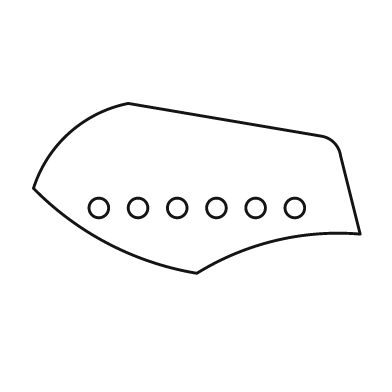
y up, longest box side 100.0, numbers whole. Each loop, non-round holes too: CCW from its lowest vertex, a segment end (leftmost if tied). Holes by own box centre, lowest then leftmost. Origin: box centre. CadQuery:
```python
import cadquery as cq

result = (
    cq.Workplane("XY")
    .moveTo(0.0, -26.0)
    .threePointArc((24.0, -16.0), (50.0, -14.0))
    .lineTo(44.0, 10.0)
    .threePointArc((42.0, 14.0), (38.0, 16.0))
    .lineTo(-21.0, 26.0)
    .threePointArc((-39.0, 17.0), (-50.0, 0.0))
    .threePointArc((-27.0, -17.0), (0.0, -26.0))
    .close()
    .moveTo(-30.0, -6.0)
    .circle(3.0)
    .moveTo(-18.0, -6.0)
    .circle(3.0)
    .moveTo(-6.0, -6.0)
    .circle(3.0)
    .moveTo(6.0, -6.0)
    .circle(3.0)
    .moveTo(18.0, -6.0)
    .circle(3.0)
    .moveTo(30.0, -6.0)
    .circle(3.0)
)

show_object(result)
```